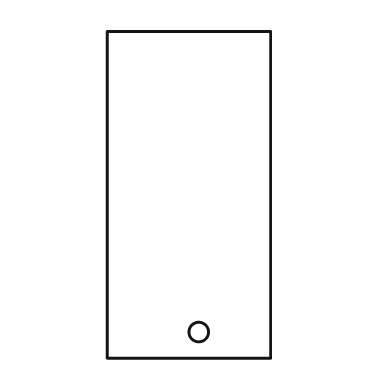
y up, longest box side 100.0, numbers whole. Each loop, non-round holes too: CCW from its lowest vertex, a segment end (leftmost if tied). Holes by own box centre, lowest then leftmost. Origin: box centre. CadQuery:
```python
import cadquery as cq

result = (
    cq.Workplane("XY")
    .moveTo(-25.0, -50.0)
    .lineTo(25.0, -50.0)
    .lineTo(25.0, 50.0)
    .lineTo(-25.0, 50.0)
    .close()
    .moveTo(3.0, -42.0)
    .circle(3.0)
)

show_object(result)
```